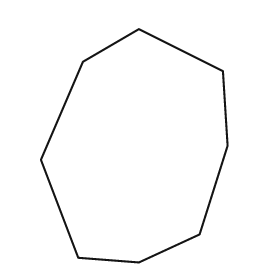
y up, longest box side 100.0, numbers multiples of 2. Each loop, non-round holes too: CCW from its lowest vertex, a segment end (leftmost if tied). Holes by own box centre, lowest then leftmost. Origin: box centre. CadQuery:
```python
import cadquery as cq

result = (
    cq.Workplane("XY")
    .moveTo(2.0, -50.0)
    .lineTo(28.0, -38.0)
    .lineTo(40.0, 0.0)
    .lineTo(38.0, 32.0)
    .lineTo(2.0, 50.0)
    .lineTo(-22.0, 36.0)
    .lineTo(-40.0, -6.0)
    .lineTo(-24.0, -48.0)
    .close()
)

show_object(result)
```